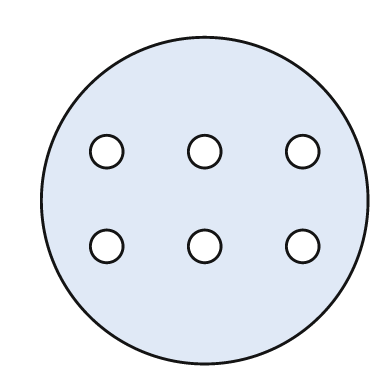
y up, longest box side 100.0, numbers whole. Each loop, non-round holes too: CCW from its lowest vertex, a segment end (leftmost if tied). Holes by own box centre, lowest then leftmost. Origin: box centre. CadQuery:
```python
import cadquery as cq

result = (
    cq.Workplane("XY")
    .moveTo(0.0, 0.0)
    .circle(50.0)
    .moveTo(-30.0, -14.0)
    .circle(5.0)
    .moveTo(0.0, -14.0)
    .circle(5.0)
    .moveTo(30.0, -14.0)
    .circle(5.0)
    .moveTo(-30.0, 15.0)
    .circle(5.0)
    .moveTo(0.0, 15.0)
    .circle(5.0)
    .moveTo(30.0, 15.0)
    .circle(5.0)
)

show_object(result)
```